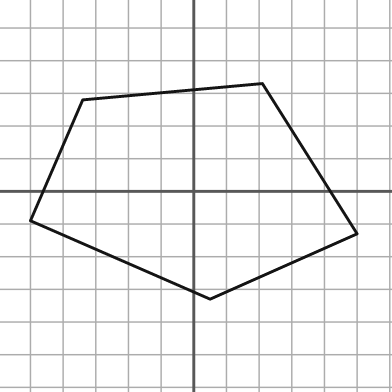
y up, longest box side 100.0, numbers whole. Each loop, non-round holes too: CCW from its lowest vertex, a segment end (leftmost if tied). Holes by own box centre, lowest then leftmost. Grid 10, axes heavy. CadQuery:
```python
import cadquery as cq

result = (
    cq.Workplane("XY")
    .moveTo(5.0, -33.0)
    .lineTo(50.0, -13.0)
    .lineTo(21.0, 33.0)
    .lineTo(-34.0, 28.0)
    .lineTo(-50.0, -9.0)
    .close()
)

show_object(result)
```